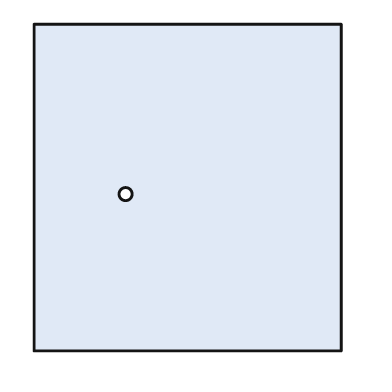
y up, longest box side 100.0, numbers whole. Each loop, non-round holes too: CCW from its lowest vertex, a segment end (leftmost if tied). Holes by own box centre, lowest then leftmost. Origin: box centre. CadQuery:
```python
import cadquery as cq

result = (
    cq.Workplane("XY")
    .moveTo(-47.0, -50.0)
    .lineTo(47.0, -50.0)
    .lineTo(47.0, 50.0)
    .lineTo(-47.0, 50.0)
    .close()
    .moveTo(-19.0, -2.0)
    .circle(2.0)
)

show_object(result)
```